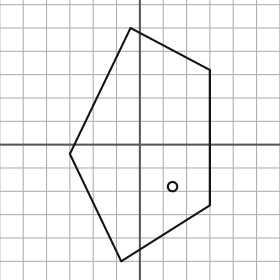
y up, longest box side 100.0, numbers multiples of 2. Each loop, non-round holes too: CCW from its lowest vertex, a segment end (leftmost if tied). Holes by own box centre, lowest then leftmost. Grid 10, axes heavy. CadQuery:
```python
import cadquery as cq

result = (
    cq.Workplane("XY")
    .moveTo(-8.0, -50.0)
    .lineTo(30.0, -26.0)
    .lineTo(30.0, 32.0)
    .lineTo(-4.0, 50.0)
    .lineTo(-30.0, -4.0)
    .close()
    .moveTo(14.0, -18.0)
    .circle(2.0)
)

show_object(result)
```